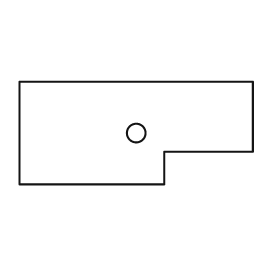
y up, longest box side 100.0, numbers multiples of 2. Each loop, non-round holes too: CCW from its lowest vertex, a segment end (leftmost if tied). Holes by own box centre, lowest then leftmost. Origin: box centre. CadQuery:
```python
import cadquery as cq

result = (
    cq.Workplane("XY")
    .moveTo(-50.0, -22.0)
    .lineTo(12.0, -22.0)
    .lineTo(12.0, -8.0)
    .lineTo(50.0, -8.0)
    .lineTo(50.0, 22.0)
    .lineTo(-50.0, 22.0)
    .close()
    .moveTo(0.0, 0.0)
    .circle(4.0)
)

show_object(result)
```